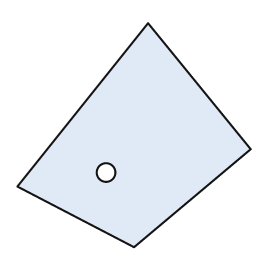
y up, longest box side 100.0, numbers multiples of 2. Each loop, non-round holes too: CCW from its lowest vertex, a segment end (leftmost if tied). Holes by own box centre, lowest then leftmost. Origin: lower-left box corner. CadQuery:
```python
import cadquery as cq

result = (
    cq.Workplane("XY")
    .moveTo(50.0, 0.0)
    .lineTo(100.0, 42.0)
    .lineTo(56.0, 96.0)
    .lineTo(0.0, 26.0)
    .close()
    .moveTo(38.0, 32.0)
    .circle(4.0)
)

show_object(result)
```